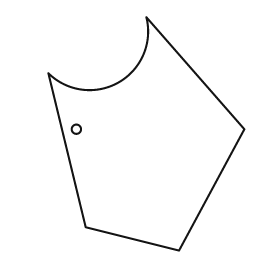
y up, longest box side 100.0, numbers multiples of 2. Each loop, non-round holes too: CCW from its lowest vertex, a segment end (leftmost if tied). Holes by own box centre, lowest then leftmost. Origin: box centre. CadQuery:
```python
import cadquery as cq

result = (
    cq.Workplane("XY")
    .moveTo(14.0, -50.0)
    .lineTo(42.0, 2.0)
    .lineTo(0.0, 50.0)
    .threePointArc((-12.0, 22.0), (-42.0, 26.0))
    .lineTo(-26.0, -40.0)
    .close()
    .moveTo(-30.0, 2.0)
    .circle(2.0)
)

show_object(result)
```